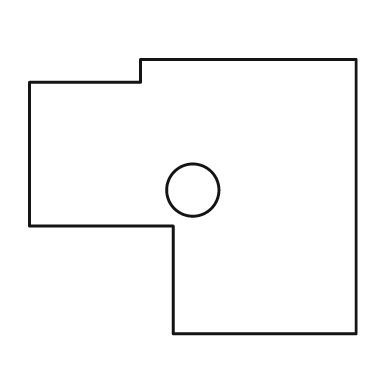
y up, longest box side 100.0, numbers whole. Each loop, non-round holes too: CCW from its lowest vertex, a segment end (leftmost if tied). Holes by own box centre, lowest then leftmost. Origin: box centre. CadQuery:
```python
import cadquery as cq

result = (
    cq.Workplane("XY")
    .moveTo(-6.0, -42.0)
    .lineTo(50.0, -42.0)
    .lineTo(50.0, 42.0)
    .lineTo(-16.0, 42.0)
    .lineTo(-16.0, 35.0)
    .lineTo(-50.0, 35.0)
    .lineTo(-50.0, -9.0)
    .lineTo(-6.0, -9.0)
    .close()
    .moveTo(0.0, 2.0)
    .circle(8.0)
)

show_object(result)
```